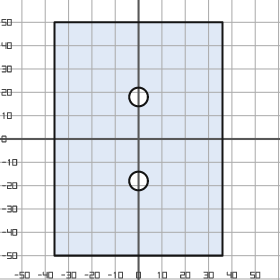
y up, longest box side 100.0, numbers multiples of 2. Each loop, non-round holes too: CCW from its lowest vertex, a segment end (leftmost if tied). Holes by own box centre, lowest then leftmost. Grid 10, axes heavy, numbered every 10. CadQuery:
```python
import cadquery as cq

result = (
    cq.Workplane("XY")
    .moveTo(-36.0, -50.0)
    .lineTo(36.0, -50.0)
    .lineTo(36.0, 50.0)
    .lineTo(-36.0, 50.0)
    .close()
    .moveTo(0.0, -18.0)
    .circle(4.0)
    .moveTo(0.0, 18.0)
    .circle(4.0)
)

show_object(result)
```